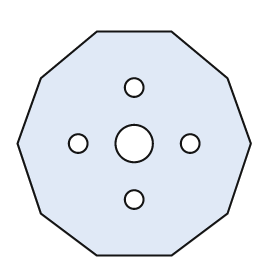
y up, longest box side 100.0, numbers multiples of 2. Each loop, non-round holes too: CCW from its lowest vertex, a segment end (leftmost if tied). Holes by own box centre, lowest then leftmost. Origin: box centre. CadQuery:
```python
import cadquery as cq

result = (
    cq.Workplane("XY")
    .moveTo(-16.0, -48.0)
    .lineTo(16.0, -48.0)
    .lineTo(40.0, -30.0)
    .lineTo(50.0, 0.0)
    .lineTo(40.0, 28.0)
    .lineTo(16.0, 48.0)
    .lineTo(-16.0, 48.0)
    .lineTo(-40.0, 28.0)
    .lineTo(-50.0, 0.0)
    .lineTo(-40.0, -30.0)
    .close()
    .moveTo(0.0, -24.0)
    .circle(4.0)
    .moveTo(-24.0, 0.0)
    .circle(4.0)
    .moveTo(0.0, 0.0)
    .circle(8.0)
    .moveTo(24.0, 0.0)
    .circle(4.0)
    .moveTo(0.0, 24.0)
    .circle(4.0)
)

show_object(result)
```